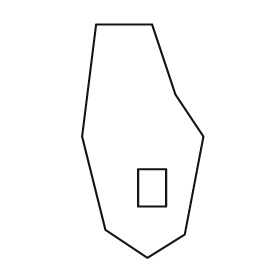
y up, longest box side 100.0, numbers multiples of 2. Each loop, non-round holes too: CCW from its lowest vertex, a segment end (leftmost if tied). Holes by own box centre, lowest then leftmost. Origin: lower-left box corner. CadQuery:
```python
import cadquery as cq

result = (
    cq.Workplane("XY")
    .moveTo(28.0, 0.0)
    .lineTo(44.0, 10.0)
    .lineTo(52.0, 52.0)
    .lineTo(40.0, 70.0)
    .lineTo(30.0, 100.0)
    .lineTo(6.0, 100.0)
    .lineTo(0.0, 52.0)
    .lineTo(10.0, 12.0)
    .close()
    .moveTo(24.0, 22.0)
    .lineTo(36.0, 22.0)
    .lineTo(36.0, 38.0)
    .lineTo(24.0, 38.0)
    .close()
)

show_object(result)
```